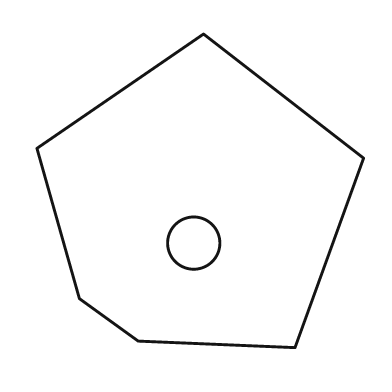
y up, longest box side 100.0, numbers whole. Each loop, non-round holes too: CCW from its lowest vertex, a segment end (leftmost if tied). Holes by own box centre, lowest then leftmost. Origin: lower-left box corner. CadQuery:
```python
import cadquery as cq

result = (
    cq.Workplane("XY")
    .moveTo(79.0, 0.0)
    .lineTo(100.0, 58.0)
    .lineTo(51.0, 96.0)
    .lineTo(0.0, 61.0)
    .lineTo(13.0, 15.0)
    .lineTo(31.0, 2.0)
    .close()
    .moveTo(48.0, 32.0)
    .circle(8.0)
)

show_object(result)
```